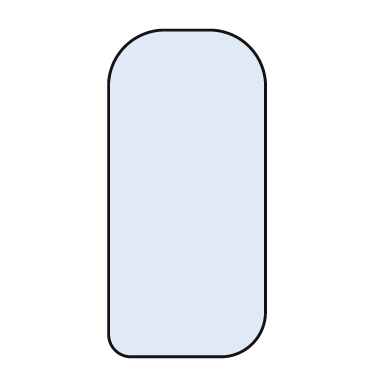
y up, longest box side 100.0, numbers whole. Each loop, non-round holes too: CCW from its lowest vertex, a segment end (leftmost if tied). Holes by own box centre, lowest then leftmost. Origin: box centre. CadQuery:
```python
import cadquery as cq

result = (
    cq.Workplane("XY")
    .moveTo(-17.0, -50.0)
    .lineTo(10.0, -50.0)
    .threePointArc((20.0, -46.0), (24.0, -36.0))
    .lineTo(24.0, 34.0)
    .threePointArc((19.0, 45.0), (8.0, 50.0))
    .lineTo(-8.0, 50.0)
    .threePointArc((-19.0, 45.0), (-24.0, 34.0))
    .lineTo(-24.0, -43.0)
    .threePointArc((-22.0, -48.0), (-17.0, -50.0))
    .close()
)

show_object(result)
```